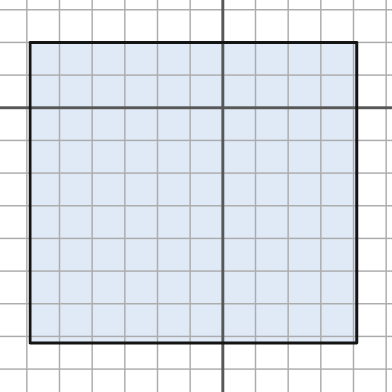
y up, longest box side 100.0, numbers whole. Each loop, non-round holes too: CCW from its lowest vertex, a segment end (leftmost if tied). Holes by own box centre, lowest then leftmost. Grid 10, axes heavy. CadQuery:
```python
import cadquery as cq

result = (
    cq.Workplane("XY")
    .moveTo(-59.0, -72.0)
    .lineTo(41.0, -72.0)
    .lineTo(41.0, 20.0)
    .lineTo(-59.0, 20.0)
    .close()
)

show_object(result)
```